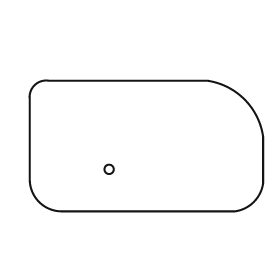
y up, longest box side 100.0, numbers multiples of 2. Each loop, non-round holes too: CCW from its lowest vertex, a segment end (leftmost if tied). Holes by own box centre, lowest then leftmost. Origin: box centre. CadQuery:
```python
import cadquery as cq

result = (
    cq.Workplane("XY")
    .moveTo(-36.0, -28.0)
    .lineTo(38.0, -28.0)
    .threePointArc((46.0, -24.0), (50.0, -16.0))
    .lineTo(50.0, 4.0)
    .threePointArc((42.0, 20.0), (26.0, 28.0))
    .lineTo(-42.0, 28.0)
    .threePointArc((-48.0, 26.0), (-50.0, 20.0))
    .lineTo(-50.0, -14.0)
    .threePointArc((-46.0, -24.0), (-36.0, -28.0))
    .close()
    .moveTo(-16.0, -10.0)
    .circle(2.0)
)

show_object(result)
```